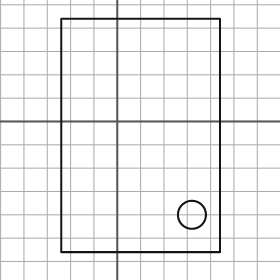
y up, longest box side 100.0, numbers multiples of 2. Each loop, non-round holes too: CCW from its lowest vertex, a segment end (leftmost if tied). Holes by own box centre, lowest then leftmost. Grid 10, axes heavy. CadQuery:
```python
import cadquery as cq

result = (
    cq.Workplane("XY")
    .moveTo(-24.0, -56.0)
    .lineTo(44.0, -56.0)
    .lineTo(44.0, 44.0)
    .lineTo(-24.0, 44.0)
    .close()
    .moveTo(32.0, -40.0)
    .circle(6.0)
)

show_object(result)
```